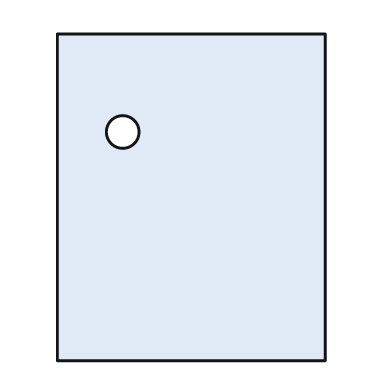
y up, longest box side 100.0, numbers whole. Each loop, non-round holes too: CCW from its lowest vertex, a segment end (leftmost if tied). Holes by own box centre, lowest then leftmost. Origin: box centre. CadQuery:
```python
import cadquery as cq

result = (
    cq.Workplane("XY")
    .moveTo(-41.0, -50.0)
    .lineTo(41.0, -50.0)
    .lineTo(41.0, 50.0)
    .lineTo(-41.0, 50.0)
    .close()
    .moveTo(-21.0, 20.0)
    .circle(5.0)
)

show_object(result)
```